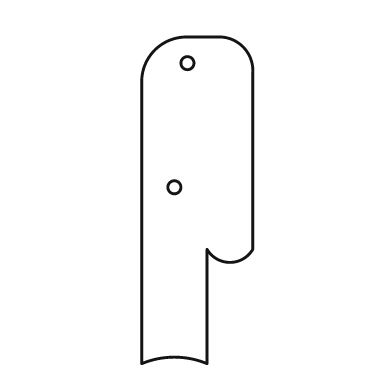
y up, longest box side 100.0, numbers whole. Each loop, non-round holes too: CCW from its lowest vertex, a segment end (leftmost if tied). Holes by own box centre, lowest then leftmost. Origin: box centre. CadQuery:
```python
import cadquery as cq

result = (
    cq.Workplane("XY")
    .moveTo(-17.0, -50.0)
    .threePointArc((-7.0, -48.0), (3.0, -50.0))
    .lineTo(3.0, -15.0)
    .threePointArc((10.0, -19.0), (17.0, -15.0))
    .lineTo(17.0, 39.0)
    .threePointArc((14.0, 47.0), (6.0, 50.0))
    .lineTo(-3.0, 50.0)
    .threePointArc((-13.0, 46.0), (-17.0, 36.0))
    .close()
    .moveTo(-7.0, 4.0)
    .circle(2.0)
    .moveTo(-3.0, 42.0)
    .circle(2.0)
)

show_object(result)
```